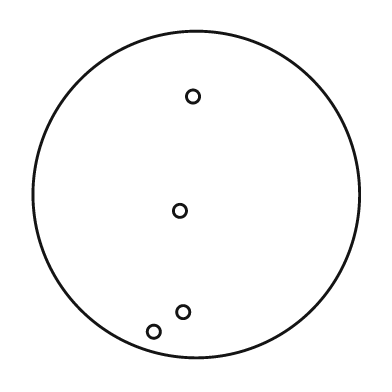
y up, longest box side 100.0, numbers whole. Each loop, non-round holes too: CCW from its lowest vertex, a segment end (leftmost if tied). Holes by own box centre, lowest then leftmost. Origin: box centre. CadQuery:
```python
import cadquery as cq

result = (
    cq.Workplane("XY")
    .moveTo(0.0, 0.0)
    .circle(50.0)
    .moveTo(-13.0, -42.0)
    .circle(2.0)
    .moveTo(-4.0, -36.0)
    .circle(2.0)
    .moveTo(-5.0, -5.0)
    .circle(2.0)
    .moveTo(-1.0, 30.0)
    .circle(2.0)
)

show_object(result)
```